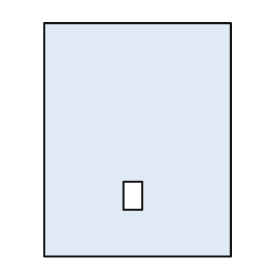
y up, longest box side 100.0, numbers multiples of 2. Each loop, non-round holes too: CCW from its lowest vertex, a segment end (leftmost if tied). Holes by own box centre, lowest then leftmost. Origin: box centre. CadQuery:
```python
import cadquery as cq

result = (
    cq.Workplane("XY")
    .moveTo(-40.0, -50.0)
    .lineTo(40.0, -50.0)
    .lineTo(40.0, 50.0)
    .lineTo(-40.0, 50.0)
    .close()
    .moveTo(-6.0, -30.0)
    .lineTo(2.0, -30.0)
    .lineTo(2.0, -18.0)
    .lineTo(-6.0, -18.0)
    .close()
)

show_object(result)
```